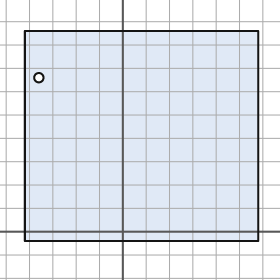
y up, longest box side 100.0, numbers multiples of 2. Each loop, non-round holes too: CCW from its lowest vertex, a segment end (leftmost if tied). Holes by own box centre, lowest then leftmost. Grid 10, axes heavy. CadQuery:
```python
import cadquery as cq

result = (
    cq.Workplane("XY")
    .moveTo(-42.0, -4.0)
    .lineTo(58.0, -4.0)
    .lineTo(58.0, 86.0)
    .lineTo(-42.0, 86.0)
    .close()
    .moveTo(-36.0, 66.0)
    .circle(2.0)
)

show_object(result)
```